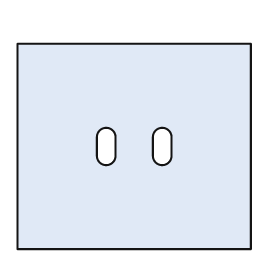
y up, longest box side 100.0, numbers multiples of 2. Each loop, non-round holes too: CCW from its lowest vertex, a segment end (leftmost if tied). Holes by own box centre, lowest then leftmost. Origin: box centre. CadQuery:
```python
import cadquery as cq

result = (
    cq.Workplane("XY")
    .moveTo(-50.0, -44.0)
    .lineTo(50.0, -44.0)
    .lineTo(50.0, 44.0)
    .lineTo(-50.0, 44.0)
    .close()
    .moveTo(-16.0, -4.0)
    .threePointArc((-12.0, -8.0), (-8.0, -4.0))
    .lineTo(-8.0, 4.0)
    .threePointArc((-12.0, 8.0), (-16.0, 4.0))
    .close()
    .moveTo(8.0, -4.0)
    .threePointArc((12.0, -8.0), (16.0, -4.0))
    .lineTo(16.0, 4.0)
    .threePointArc((12.0, 8.0), (8.0, 4.0))
    .close()
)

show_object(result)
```